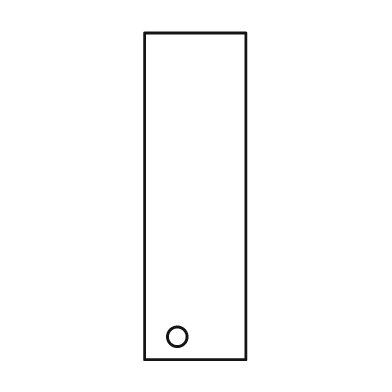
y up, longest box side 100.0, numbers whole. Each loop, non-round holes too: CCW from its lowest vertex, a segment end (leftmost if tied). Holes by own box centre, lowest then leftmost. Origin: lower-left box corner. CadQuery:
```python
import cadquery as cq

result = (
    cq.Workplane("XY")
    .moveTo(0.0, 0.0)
    .lineTo(31.0, 0.0)
    .lineTo(31.0, 100.0)
    .lineTo(0.0, 100.0)
    .close()
    .moveTo(10.0, 7.0)
    .circle(3.0)
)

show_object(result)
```